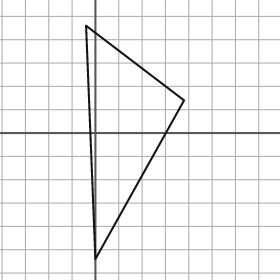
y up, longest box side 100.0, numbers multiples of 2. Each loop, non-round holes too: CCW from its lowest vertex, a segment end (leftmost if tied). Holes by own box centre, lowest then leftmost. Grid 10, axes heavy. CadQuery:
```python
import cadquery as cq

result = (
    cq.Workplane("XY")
    .moveTo(0.0, -54.0)
    .lineTo(38.0, 14.0)
    .lineTo(-4.0, 46.0)
    .close()
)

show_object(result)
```